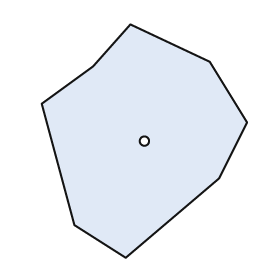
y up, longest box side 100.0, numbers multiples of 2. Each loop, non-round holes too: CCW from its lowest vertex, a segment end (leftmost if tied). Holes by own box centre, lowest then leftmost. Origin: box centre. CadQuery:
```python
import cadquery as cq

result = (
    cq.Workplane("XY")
    .moveTo(-8.0, -50.0)
    .lineTo(32.0, -16.0)
    .lineTo(44.0, 8.0)
    .lineTo(28.0, 34.0)
    .lineTo(-6.0, 50.0)
    .lineTo(-22.0, 32.0)
    .lineTo(-44.0, 16.0)
    .lineTo(-30.0, -36.0)
    .close()
    .moveTo(0.0, 0.0)
    .circle(2.0)
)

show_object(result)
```